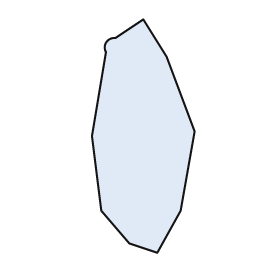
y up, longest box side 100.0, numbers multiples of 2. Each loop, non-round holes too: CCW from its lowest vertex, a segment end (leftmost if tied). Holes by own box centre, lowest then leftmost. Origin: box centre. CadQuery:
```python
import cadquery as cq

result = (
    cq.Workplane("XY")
    .moveTo(6.0, -50.0)
    .lineTo(16.0, -32.0)
    .lineTo(22.0, 2.0)
    .lineTo(10.0, 34.0)
    .lineTo(0.0, 50.0)
    .lineTo(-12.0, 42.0)
    .threePointArc((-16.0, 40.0), (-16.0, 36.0))
    .lineTo(-22.0, 0.0)
    .lineTo(-18.0, -32.0)
    .lineTo(-6.0, -46.0)
    .close()
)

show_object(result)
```